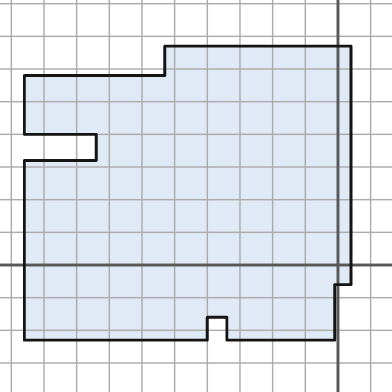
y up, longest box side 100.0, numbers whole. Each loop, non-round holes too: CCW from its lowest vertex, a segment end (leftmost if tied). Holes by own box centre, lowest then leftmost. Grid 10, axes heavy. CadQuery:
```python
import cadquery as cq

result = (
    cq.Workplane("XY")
    .moveTo(-96.0, -23.0)
    .lineTo(-40.0, -23.0)
    .lineTo(-40.0, -16.0)
    .lineTo(-34.0, -16.0)
    .lineTo(-34.0, -23.0)
    .lineTo(-1.0, -23.0)
    .lineTo(-1.0, -6.0)
    .lineTo(4.0, -6.0)
    .lineTo(4.0, 67.0)
    .lineTo(-53.0, 67.0)
    .lineTo(-53.0, 58.0)
    .lineTo(-96.0, 58.0)
    .lineTo(-96.0, 40.0)
    .lineTo(-74.0, 40.0)
    .lineTo(-74.0, 32.0)
    .lineTo(-96.0, 32.0)
    .close()
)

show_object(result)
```